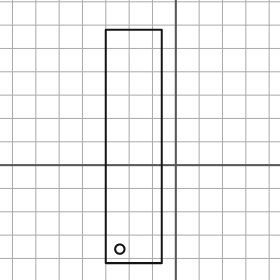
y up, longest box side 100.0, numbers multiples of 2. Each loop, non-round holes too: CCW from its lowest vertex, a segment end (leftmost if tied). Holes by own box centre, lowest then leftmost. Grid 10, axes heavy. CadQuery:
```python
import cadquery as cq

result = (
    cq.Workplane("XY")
    .moveTo(-30.0, -42.0)
    .lineTo(-6.0, -42.0)
    .lineTo(-6.0, 58.0)
    .lineTo(-30.0, 58.0)
    .close()
    .moveTo(-24.0, -36.0)
    .circle(2.0)
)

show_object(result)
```